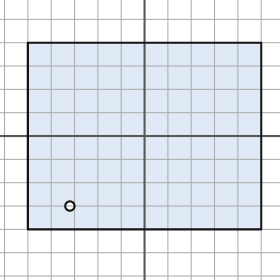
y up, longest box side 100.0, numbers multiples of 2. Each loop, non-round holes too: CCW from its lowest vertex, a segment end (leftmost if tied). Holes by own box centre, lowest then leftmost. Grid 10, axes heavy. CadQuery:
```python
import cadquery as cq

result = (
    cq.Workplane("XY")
    .moveTo(-50.0, -40.0)
    .lineTo(50.0, -40.0)
    .lineTo(50.0, 40.0)
    .lineTo(-50.0, 40.0)
    .close()
    .moveTo(-32.0, -30.0)
    .circle(2.0)
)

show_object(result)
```